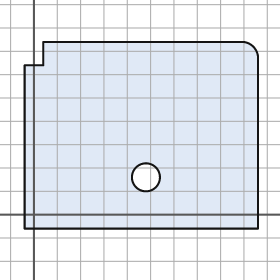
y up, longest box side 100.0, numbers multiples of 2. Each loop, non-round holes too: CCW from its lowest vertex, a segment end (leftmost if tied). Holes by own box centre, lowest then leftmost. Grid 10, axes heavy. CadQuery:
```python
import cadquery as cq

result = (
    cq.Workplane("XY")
    .moveTo(-4.0, -6.0)
    .lineTo(96.0, -6.0)
    .lineTo(96.0, 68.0)
    .threePointArc((94.0, 72.0), (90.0, 74.0))
    .lineTo(4.0, 74.0)
    .lineTo(4.0, 64.0)
    .lineTo(-4.0, 64.0)
    .close()
    .moveTo(48.0, 16.0)
    .circle(6.0)
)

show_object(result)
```